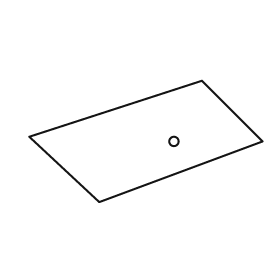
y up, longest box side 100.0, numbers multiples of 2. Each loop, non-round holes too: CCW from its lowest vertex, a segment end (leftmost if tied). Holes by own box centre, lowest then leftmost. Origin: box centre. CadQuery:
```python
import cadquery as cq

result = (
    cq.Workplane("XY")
    .moveTo(-20.0, -26.0)
    .lineTo(50.0, 0.0)
    .lineTo(24.0, 26.0)
    .lineTo(-50.0, 2.0)
    .close()
    .moveTo(12.0, 0.0)
    .circle(2.0)
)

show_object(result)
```